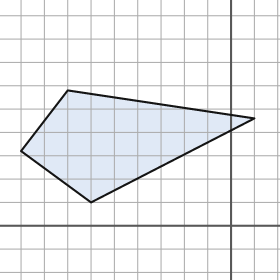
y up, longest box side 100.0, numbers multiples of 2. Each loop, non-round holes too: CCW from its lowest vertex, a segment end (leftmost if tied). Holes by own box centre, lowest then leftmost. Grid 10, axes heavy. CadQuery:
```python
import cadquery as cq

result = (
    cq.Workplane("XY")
    .moveTo(-60.0, 10.0)
    .lineTo(10.0, 46.0)
    .lineTo(-70.0, 58.0)
    .lineTo(-90.0, 32.0)
    .close()
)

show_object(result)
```